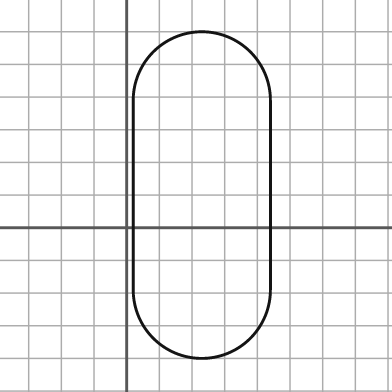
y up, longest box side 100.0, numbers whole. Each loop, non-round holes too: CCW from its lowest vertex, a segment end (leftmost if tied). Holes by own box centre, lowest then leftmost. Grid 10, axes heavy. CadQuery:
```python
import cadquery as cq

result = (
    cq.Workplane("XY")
    .moveTo(2.0, -19.0)
    .threePointArc((23.0, -40.0), (44.0, -19.0))
    .lineTo(44.0, 39.0)
    .threePointArc((23.0, 60.0), (2.0, 39.0))
    .close()
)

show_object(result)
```